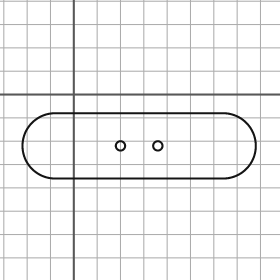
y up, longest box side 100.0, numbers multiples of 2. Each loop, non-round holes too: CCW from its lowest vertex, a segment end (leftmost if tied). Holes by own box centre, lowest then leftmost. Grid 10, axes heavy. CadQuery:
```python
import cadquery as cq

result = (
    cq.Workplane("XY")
    .moveTo(-8.0, -36.0)
    .lineTo(64.0, -36.0)
    .threePointArc((78.0, -22.0), (64.0, -8.0))
    .lineTo(-8.0, -8.0)
    .threePointArc((-22.0, -22.0), (-8.0, -36.0))
    .close()
    .moveTo(20.0, -22.0)
    .circle(2.0)
    .moveTo(36.0, -22.0)
    .circle(2.0)
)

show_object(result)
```